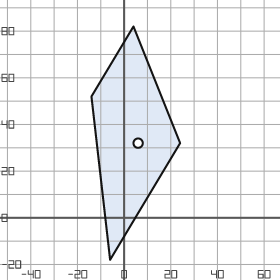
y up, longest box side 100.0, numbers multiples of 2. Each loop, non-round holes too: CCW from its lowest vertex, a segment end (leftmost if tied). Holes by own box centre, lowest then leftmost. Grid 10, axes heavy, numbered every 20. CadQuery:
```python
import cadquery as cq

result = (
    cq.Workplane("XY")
    .moveTo(-6.0, -18.0)
    .lineTo(24.0, 32.0)
    .lineTo(4.0, 82.0)
    .lineTo(-14.0, 52.0)
    .close()
    .moveTo(6.0, 32.0)
    .circle(2.0)
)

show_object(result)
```